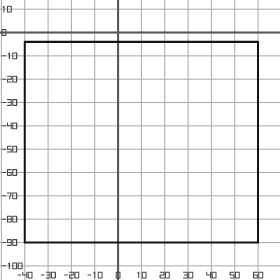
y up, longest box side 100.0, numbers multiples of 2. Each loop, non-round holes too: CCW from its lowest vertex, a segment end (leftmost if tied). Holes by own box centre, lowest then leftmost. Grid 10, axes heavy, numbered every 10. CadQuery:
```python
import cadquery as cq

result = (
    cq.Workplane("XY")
    .moveTo(-40.0, -90.0)
    .lineTo(60.0, -90.0)
    .lineTo(60.0, -4.0)
    .lineTo(-40.0, -4.0)
    .close()
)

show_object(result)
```